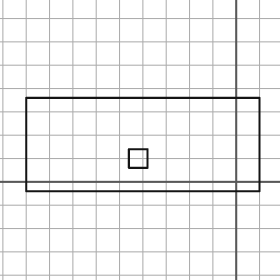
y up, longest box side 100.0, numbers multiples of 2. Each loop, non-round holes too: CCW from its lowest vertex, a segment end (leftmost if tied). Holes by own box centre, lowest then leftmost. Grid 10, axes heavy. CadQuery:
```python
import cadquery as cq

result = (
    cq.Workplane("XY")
    .moveTo(-90.0, -4.0)
    .lineTo(10.0, -4.0)
    .lineTo(10.0, 36.0)
    .lineTo(-90.0, 36.0)
    .close()
    .moveTo(-46.0, 6.0)
    .lineTo(-38.0, 6.0)
    .lineTo(-38.0, 14.0)
    .lineTo(-46.0, 14.0)
    .close()
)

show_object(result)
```